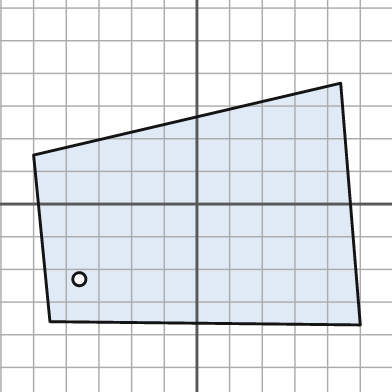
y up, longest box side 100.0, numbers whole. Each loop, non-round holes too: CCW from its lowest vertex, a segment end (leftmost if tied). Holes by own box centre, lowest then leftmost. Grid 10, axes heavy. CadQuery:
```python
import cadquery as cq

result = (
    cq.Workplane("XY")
    .moveTo(50.0, -37.0)
    .lineTo(44.0, 37.0)
    .lineTo(-50.0, 15.0)
    .lineTo(-45.0, -36.0)
    .close()
    .moveTo(-36.0, -23.0)
    .circle(2.0)
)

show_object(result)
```